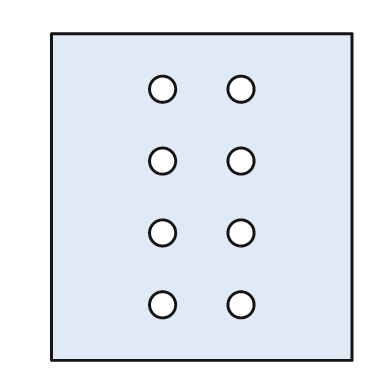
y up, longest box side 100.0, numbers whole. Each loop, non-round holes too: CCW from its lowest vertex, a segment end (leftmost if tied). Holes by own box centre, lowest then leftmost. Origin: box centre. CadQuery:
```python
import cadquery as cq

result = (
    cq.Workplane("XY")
    .moveTo(-46.0, -50.0)
    .lineTo(46.0, -50.0)
    .lineTo(46.0, 50.0)
    .lineTo(-46.0, 50.0)
    .close()
    .moveTo(-12.0, -33.0)
    .circle(4.0)
    .moveTo(12.0, -33.0)
    .circle(4.0)
    .moveTo(-12.0, -11.0)
    .circle(4.0)
    .moveTo(12.0, -11.0)
    .circle(4.0)
    .moveTo(-12.0, 11.0)
    .circle(4.0)
    .moveTo(12.0, 11.0)
    .circle(4.0)
    .moveTo(-12.0, 33.0)
    .circle(4.0)
    .moveTo(12.0, 33.0)
    .circle(4.0)
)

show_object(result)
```